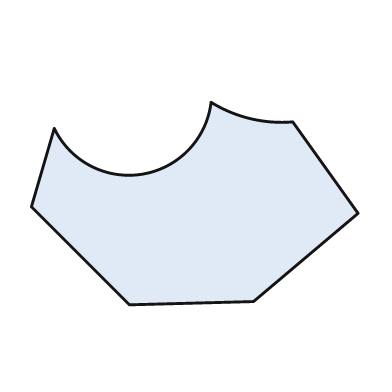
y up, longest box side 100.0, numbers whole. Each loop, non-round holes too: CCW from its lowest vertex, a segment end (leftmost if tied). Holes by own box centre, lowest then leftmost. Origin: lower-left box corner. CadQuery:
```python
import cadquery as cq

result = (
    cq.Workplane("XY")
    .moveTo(30.0, 0.0)
    .lineTo(68.0, 1.0)
    .lineTo(100.0, 28.0)
    .lineTo(80.0, 56.0)
    .threePointArc((67.0, 57.0), (55.0, 62.0))
    .threePointArc((34.0, 40.0), (7.0, 54.0))
    .lineTo(0.0, 30.0)
    .close()
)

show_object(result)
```